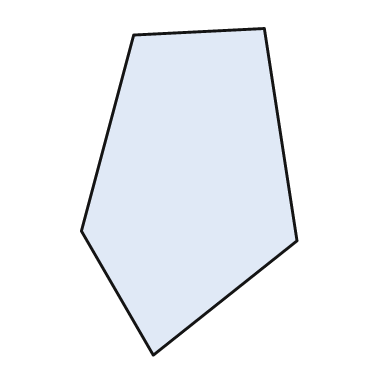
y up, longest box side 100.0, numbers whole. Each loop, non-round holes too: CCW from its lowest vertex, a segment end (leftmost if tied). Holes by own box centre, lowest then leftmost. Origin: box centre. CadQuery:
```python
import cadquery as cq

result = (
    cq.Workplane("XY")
    .moveTo(-11.0, -50.0)
    .lineTo(33.0, -15.0)
    .lineTo(23.0, 50.0)
    .lineTo(-17.0, 48.0)
    .lineTo(-33.0, -12.0)
    .close()
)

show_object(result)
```